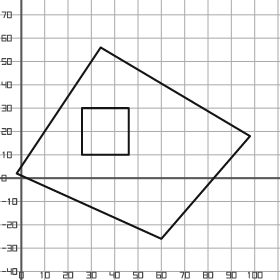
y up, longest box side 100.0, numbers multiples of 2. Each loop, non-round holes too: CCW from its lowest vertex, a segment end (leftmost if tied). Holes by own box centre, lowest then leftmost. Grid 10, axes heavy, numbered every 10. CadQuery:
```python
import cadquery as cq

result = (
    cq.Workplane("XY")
    .moveTo(60.0, -26.0)
    .lineTo(98.0, 18.0)
    .lineTo(34.0, 56.0)
    .lineTo(-2.0, 2.0)
    .close()
    .moveTo(26.0, 10.0)
    .lineTo(46.0, 10.0)
    .lineTo(46.0, 30.0)
    .lineTo(26.0, 30.0)
    .close()
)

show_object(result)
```